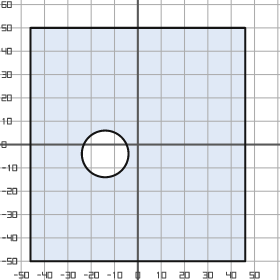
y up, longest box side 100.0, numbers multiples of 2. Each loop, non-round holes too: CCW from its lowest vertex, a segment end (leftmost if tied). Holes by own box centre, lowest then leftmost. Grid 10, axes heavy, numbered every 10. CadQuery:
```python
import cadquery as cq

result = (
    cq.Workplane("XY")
    .moveTo(-46.0, -50.0)
    .lineTo(46.0, -50.0)
    .lineTo(46.0, 50.0)
    .lineTo(-46.0, 50.0)
    .close()
    .moveTo(-14.0, -4.0)
    .circle(10.0)
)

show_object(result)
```